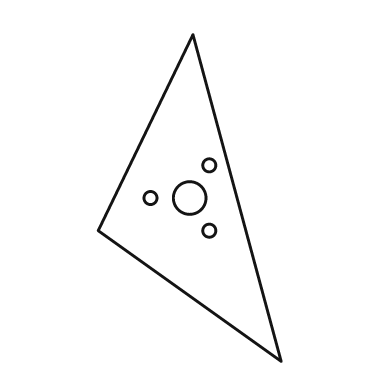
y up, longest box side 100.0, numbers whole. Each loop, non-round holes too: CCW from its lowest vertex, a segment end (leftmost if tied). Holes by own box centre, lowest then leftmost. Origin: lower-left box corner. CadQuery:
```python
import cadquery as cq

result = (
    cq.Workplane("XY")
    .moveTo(56.0, 0.0)
    .lineTo(29.0, 100.0)
    .lineTo(0.0, 40.0)
    .close()
    .moveTo(34.0, 40.0)
    .circle(2.0)
    .moveTo(16.0, 50.0)
    .circle(2.0)
    .moveTo(28.0, 50.0)
    .circle(5.0)
    .moveTo(34.0, 60.0)
    .circle(2.0)
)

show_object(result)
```